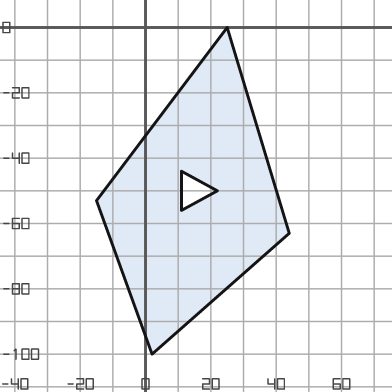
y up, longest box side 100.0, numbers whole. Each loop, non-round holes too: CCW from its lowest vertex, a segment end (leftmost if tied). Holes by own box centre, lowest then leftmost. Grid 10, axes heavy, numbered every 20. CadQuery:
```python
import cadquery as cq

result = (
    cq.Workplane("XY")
    .moveTo(2.0, -100.0)
    .lineTo(44.0, -63.0)
    .lineTo(25.0, 0.0)
    .lineTo(-15.0, -53.0)
    .close()
    .moveTo(11.0, -56.0)
    .lineTo(22.0, -50.0)
    .lineTo(11.0, -44.0)
    .close()
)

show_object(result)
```